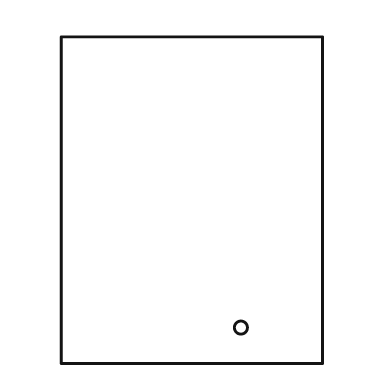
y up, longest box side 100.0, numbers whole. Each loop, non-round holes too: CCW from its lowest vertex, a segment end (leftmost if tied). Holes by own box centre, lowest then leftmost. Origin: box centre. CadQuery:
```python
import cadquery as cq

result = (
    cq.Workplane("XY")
    .moveTo(-40.0, -50.0)
    .lineTo(40.0, -50.0)
    .lineTo(40.0, 50.0)
    .lineTo(-40.0, 50.0)
    .close()
    .moveTo(15.0, -39.0)
    .circle(2.0)
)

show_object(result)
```